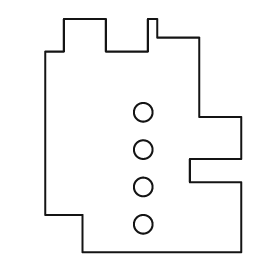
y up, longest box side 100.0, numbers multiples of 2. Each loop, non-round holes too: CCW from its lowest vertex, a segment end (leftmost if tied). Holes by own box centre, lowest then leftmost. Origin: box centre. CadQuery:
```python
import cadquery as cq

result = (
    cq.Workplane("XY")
    .moveTo(-26.0, -50.0)
    .lineTo(42.0, -50.0)
    .lineTo(42.0, -20.0)
    .lineTo(20.0, -20.0)
    .lineTo(20.0, -10.0)
    .lineTo(42.0, -10.0)
    .lineTo(42.0, 8.0)
    .lineTo(24.0, 8.0)
    .lineTo(24.0, 42.0)
    .lineTo(6.0, 42.0)
    .lineTo(6.0, 50.0)
    .lineTo(2.0, 50.0)
    .lineTo(2.0, 36.0)
    .lineTo(-16.0, 36.0)
    .lineTo(-16.0, 50.0)
    .lineTo(-34.0, 50.0)
    .lineTo(-34.0, 36.0)
    .lineTo(-42.0, 36.0)
    .lineTo(-42.0, -34.0)
    .lineTo(-26.0, -34.0)
    .close()
    .moveTo(0.0, -38.0)
    .circle(4.0)
    .moveTo(0.0, -22.0)
    .circle(4.0)
    .moveTo(0.0, -6.0)
    .circle(4.0)
    .moveTo(0.0, 10.0)
    .circle(4.0)
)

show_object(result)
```